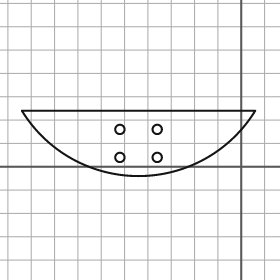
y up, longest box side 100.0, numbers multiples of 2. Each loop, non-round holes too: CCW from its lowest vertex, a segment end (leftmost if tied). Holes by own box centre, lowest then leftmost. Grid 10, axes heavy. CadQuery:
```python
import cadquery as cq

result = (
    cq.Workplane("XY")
    .moveTo(-94.0, 24.0)
    .threePointArc((-44.0, -4.0), (6.0, 24.0))
    .close()
    .moveTo(-52.0, 4.0)
    .circle(2.0)
    .moveTo(-36.0, 4.0)
    .circle(2.0)
    .moveTo(-52.0, 16.0)
    .circle(2.0)
    .moveTo(-36.0, 16.0)
    .circle(2.0)
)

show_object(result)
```